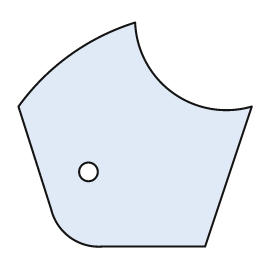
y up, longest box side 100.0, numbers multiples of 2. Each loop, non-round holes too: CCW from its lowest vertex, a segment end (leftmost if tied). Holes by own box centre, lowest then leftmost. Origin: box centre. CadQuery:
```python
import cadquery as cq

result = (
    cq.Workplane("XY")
    .moveTo(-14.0, -48.0)
    .lineTo(30.0, -48.0)
    .lineTo(50.0, 12.0)
    .threePointArc((16.0, 18.0), (0.0, 48.0))
    .threePointArc((-28.0, 34.0), (-50.0, 12.0))
    .lineTo(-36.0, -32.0)
    .threePointArc((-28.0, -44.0), (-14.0, -48.0))
    .close()
    .moveTo(-20.0, -16.0)
    .circle(4.0)
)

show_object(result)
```